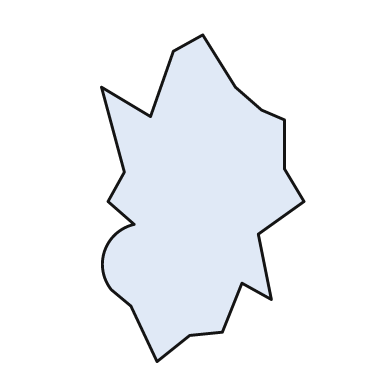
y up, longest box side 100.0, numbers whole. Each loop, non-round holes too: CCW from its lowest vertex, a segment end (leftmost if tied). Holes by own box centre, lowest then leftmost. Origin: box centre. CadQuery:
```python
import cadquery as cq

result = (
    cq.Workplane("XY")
    .moveTo(-14.0, -50.0)
    .lineTo(-4.0, -42.0)
    .lineTo(6.0, -41.0)
    .lineTo(12.0, -26.0)
    .lineTo(21.0, -31.0)
    .lineTo(17.0, -11.0)
    .lineTo(31.0, -1.0)
    .lineTo(25.0, 9.0)
    .lineTo(25.0, 24.0)
    .lineTo(18.0, 27.0)
    .lineTo(10.0, 34.0)
    .lineTo(0.0, 50.0)
    .lineTo(-9.0, 45.0)
    .lineTo(-16.0, 25.0)
    .lineTo(-31.0, 34.0)
    .lineTo(-24.0, 8.0)
    .lineTo(-29.0, -1.0)
    .lineTo(-21.0, -8.0)
    .threePointArc((-30.0, -16.0), (-28.0, -28.0))
    .lineTo(-22.0, -33.0)
    .close()
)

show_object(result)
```